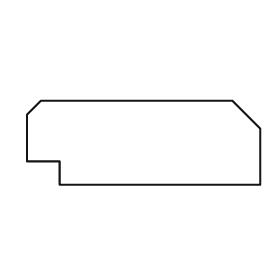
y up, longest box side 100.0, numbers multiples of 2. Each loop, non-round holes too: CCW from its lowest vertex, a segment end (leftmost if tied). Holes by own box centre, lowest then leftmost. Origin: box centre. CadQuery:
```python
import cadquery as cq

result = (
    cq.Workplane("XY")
    .moveTo(-36.0, -18.0)
    .lineTo(50.0, -18.0)
    .lineTo(50.0, 6.0)
    .lineTo(38.0, 18.0)
    .lineTo(-44.0, 18.0)
    .lineTo(-50.0, 12.0)
    .lineTo(-50.0, -8.0)
    .lineTo(-36.0, -8.0)
    .close()
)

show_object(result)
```